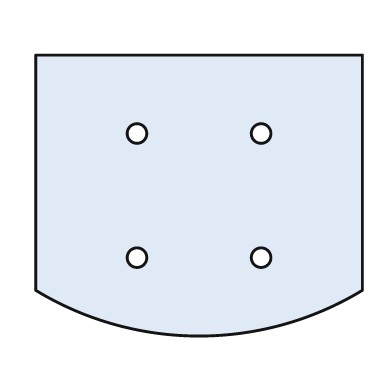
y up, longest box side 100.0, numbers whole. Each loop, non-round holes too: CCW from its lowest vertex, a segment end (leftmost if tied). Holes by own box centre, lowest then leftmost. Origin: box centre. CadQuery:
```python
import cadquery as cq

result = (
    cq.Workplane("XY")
    .moveTo(-50.0, -29.0)
    .threePointArc((0.0, -43.0), (50.0, -29.0))
    .lineTo(50.0, 43.0)
    .lineTo(-50.0, 43.0)
    .close()
    .moveTo(-19.0, -19.0)
    .circle(3.0)
    .moveTo(19.0, -19.0)
    .circle(3.0)
    .moveTo(-19.0, 19.0)
    .circle(3.0)
    .moveTo(19.0, 19.0)
    .circle(3.0)
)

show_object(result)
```